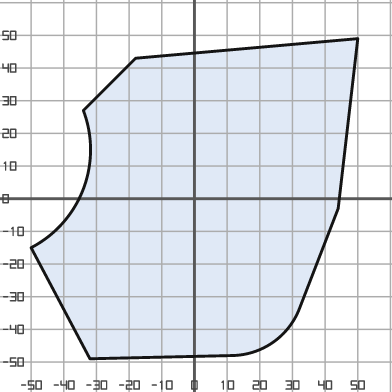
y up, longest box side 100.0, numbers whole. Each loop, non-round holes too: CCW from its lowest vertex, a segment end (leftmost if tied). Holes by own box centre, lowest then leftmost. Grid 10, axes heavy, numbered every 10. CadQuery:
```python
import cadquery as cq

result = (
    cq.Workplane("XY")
    .moveTo(-32.0, -49.0)
    .lineTo(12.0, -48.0)
    .threePointArc((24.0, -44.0), (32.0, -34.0))
    .lineTo(44.0, -3.0)
    .lineTo(50.0, 49.0)
    .lineTo(-18.0, 43.0)
    .lineTo(-34.0, 27.0)
    .threePointArc((-34.0, 3.0), (-50.0, -15.0))
    .close()
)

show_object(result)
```